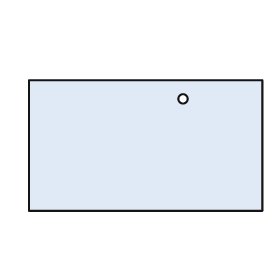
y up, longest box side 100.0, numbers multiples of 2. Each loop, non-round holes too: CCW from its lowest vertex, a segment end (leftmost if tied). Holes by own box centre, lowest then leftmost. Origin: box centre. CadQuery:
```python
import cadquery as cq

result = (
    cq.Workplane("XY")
    .moveTo(-50.0, -28.0)
    .lineTo(50.0, -28.0)
    .lineTo(50.0, 28.0)
    .lineTo(-50.0, 28.0)
    .close()
    .moveTo(16.0, 20.0)
    .circle(2.0)
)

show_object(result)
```